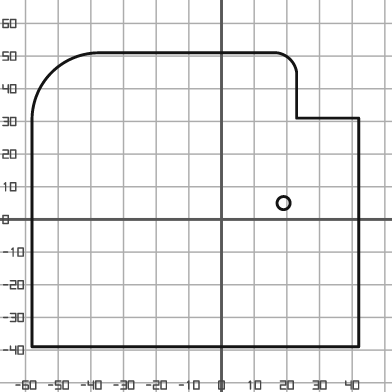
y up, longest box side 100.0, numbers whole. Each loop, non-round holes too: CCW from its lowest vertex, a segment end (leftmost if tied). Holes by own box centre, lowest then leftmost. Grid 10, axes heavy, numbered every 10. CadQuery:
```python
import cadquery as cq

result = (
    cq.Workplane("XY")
    .moveTo(-58.0, -39.0)
    .lineTo(42.0, -39.0)
    .lineTo(42.0, 31.0)
    .lineTo(23.0, 31.0)
    .lineTo(23.0, 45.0)
    .threePointArc((21.0, 49.0), (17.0, 51.0))
    .lineTo(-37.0, 51.0)
    .threePointArc((-52.0, 45.0), (-58.0, 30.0))
    .close()
    .moveTo(19.0, 5.0)
    .circle(2.0)
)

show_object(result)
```